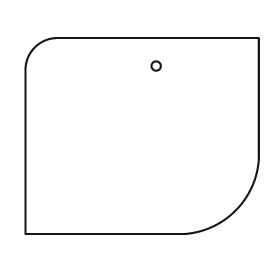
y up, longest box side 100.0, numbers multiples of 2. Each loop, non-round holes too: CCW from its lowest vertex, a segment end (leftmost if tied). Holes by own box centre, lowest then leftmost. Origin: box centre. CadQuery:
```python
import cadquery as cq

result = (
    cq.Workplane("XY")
    .moveTo(-50.0, -42.0)
    .lineTo(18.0, -42.0)
    .threePointArc((40.0, -32.0), (50.0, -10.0))
    .lineTo(50.0, 42.0)
    .lineTo(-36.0, 42.0)
    .threePointArc((-46.0, 38.0), (-50.0, 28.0))
    .close()
    .moveTo(6.0, 30.0)
    .circle(2.0)
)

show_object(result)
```